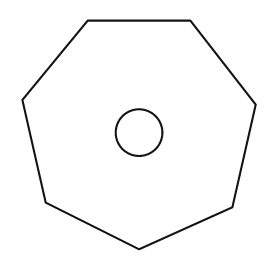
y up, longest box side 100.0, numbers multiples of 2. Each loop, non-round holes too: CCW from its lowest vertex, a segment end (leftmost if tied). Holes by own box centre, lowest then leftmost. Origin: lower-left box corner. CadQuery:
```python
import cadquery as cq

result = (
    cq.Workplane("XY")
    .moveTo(50.0, 0.0)
    .lineTo(90.0, 18.0)
    .lineTo(100.0, 62.0)
    .lineTo(72.0, 98.0)
    .lineTo(28.0, 98.0)
    .lineTo(0.0, 64.0)
    .lineTo(10.0, 20.0)
    .close()
    .moveTo(50.0, 50.0)
    .circle(10.0)
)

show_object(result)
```